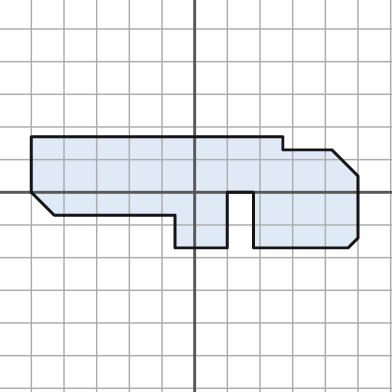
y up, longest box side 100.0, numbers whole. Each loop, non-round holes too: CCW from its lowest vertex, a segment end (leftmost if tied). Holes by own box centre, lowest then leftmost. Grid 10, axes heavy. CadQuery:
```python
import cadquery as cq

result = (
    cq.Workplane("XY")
    .moveTo(-6.0, -17.0)
    .lineTo(10.0, -17.0)
    .lineTo(10.0, 0.0)
    .lineTo(18.0, 0.0)
    .lineTo(18.0, -17.0)
    .lineTo(47.0, -17.0)
    .lineTo(50.0, -14.0)
    .lineTo(50.0, 5.0)
    .lineTo(42.0, 13.0)
    .lineTo(27.0, 13.0)
    .lineTo(27.0, 17.0)
    .lineTo(-50.0, 17.0)
    .lineTo(-50.0, 0.0)
    .lineTo(-43.0, -7.0)
    .lineTo(-6.0, -7.0)
    .close()
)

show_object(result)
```